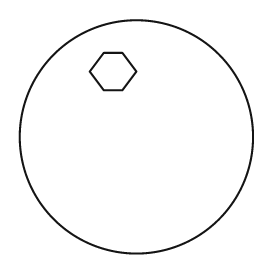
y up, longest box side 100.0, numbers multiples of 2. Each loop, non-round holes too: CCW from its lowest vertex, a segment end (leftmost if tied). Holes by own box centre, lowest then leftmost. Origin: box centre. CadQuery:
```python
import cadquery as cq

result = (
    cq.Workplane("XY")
    .moveTo(0.0, 0.0)
    .circle(50.0)
    .moveTo(-14.0, 20.0)
    .lineTo(-6.0, 20.0)
    .lineTo(0.0, 28.0)
    .lineTo(-6.0, 36.0)
    .lineTo(-14.0, 36.0)
    .lineTo(-20.0, 28.0)
    .close()
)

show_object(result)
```